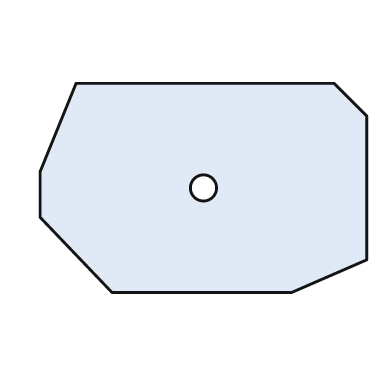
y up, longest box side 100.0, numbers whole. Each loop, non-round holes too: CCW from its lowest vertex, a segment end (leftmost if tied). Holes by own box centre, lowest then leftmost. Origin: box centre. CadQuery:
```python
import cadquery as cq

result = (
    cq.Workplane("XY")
    .moveTo(-28.0, -32.0)
    .lineTo(27.0, -32.0)
    .lineTo(50.0, -22.0)
    .lineTo(50.0, 22.0)
    .lineTo(40.0, 32.0)
    .lineTo(-39.0, 32.0)
    .lineTo(-50.0, 5.0)
    .lineTo(-50.0, -9.0)
    .close()
    .moveTo(0.0, 0.0)
    .circle(4.0)
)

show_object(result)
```